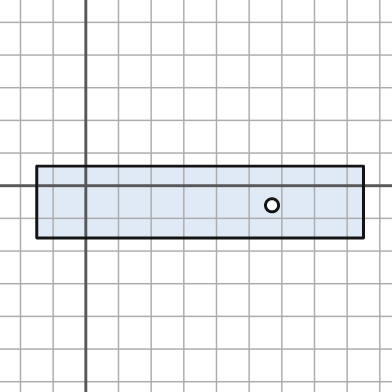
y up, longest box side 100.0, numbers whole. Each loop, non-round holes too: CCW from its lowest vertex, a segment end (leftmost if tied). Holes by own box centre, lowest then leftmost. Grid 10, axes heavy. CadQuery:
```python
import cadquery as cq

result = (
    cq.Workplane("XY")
    .moveTo(-15.0, -16.0)
    .lineTo(85.0, -16.0)
    .lineTo(85.0, 6.0)
    .lineTo(-15.0, 6.0)
    .close()
    .moveTo(57.0, -6.0)
    .circle(2.0)
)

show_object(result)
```